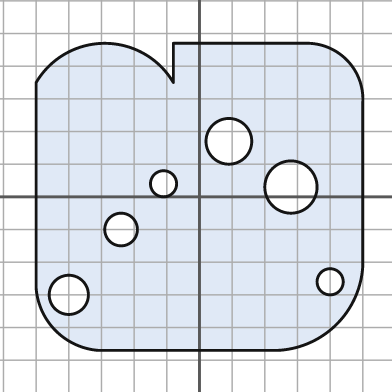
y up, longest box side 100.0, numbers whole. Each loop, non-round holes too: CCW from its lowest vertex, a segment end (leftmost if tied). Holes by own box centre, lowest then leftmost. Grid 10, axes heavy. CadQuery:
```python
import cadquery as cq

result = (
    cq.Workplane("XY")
    .moveTo(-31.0, -47.0)
    .lineTo(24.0, -47.0)
    .threePointArc((42.0, -39.0), (50.0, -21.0))
    .lineTo(50.0, 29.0)
    .threePointArc((45.0, 42.0), (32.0, 47.0))
    .lineTo(-8.0, 47.0)
    .lineTo(-8.0, 35.0)
    .threePointArc((-29.0, 47.0), (-50.0, 35.0))
    .lineTo(-50.0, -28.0)
    .threePointArc((-44.0, -41.0), (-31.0, -47.0))
    .close()
    .moveTo(-40.0, -30.0)
    .circle(6.0)
    .moveTo(40.0, -26.0)
    .circle(4.0)
    .moveTo(-24.0, -10.0)
    .circle(5.0)
    .moveTo(28.0, 3.0)
    .circle(8.0)
    .moveTo(-11.0, 4.0)
    .circle(4.0)
    .moveTo(9.0, 17.0)
    .circle(7.0)
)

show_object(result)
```